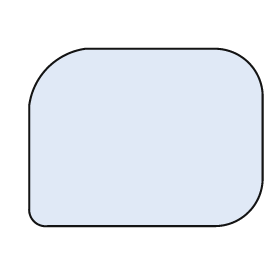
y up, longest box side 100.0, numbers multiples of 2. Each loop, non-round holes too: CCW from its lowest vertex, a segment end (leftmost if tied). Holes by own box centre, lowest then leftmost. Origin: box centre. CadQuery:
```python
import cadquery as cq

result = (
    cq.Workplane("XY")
    .moveTo(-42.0, -38.0)
    .lineTo(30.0, -38.0)
    .threePointArc((44.0, -32.0), (50.0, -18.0))
    .lineTo(50.0, 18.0)
    .threePointArc((44.0, 32.0), (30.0, 38.0))
    .lineTo(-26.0, 38.0)
    .threePointArc((-42.0, 30.0), (-50.0, 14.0))
    .lineTo(-50.0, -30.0)
    .threePointArc((-48.0, -36.0), (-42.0, -38.0))
    .close()
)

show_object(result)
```